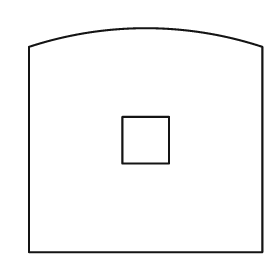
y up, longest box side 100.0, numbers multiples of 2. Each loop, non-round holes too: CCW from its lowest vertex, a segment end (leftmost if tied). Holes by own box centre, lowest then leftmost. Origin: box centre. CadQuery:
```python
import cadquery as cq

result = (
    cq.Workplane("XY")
    .moveTo(-50.0, -48.0)
    .lineTo(50.0, -48.0)
    .lineTo(50.0, 40.0)
    .threePointArc((0.0, 48.0), (-50.0, 40.0))
    .close()
    .moveTo(-10.0, -10.0)
    .lineTo(10.0, -10.0)
    .lineTo(10.0, 10.0)
    .lineTo(-10.0, 10.0)
    .close()
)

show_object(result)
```